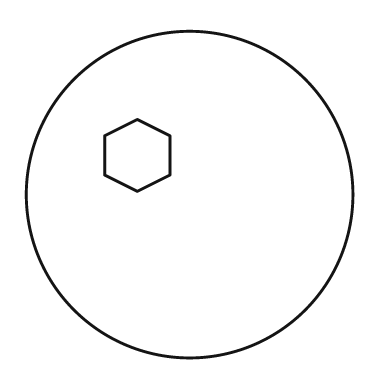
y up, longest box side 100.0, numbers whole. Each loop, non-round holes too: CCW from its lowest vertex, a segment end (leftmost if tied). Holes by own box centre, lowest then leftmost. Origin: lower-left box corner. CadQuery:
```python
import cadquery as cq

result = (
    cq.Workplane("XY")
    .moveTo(50.0, 50.0)
    .circle(50.0)
    .moveTo(34.0, 51.0)
    .lineTo(44.0, 56.0)
    .lineTo(44.0, 68.0)
    .lineTo(34.0, 73.0)
    .lineTo(24.0, 68.0)
    .lineTo(24.0, 56.0)
    .close()
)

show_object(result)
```